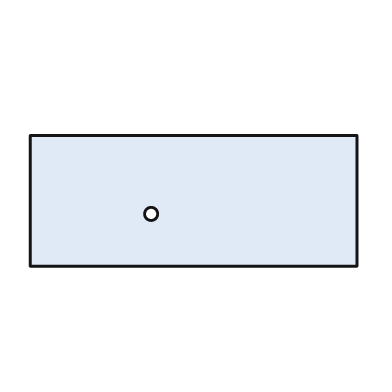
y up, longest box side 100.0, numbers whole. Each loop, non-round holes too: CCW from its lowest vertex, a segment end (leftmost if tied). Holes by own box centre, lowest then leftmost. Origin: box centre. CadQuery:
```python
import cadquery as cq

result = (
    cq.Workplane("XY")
    .moveTo(-50.0, -20.0)
    .lineTo(50.0, -20.0)
    .lineTo(50.0, 20.0)
    .lineTo(-50.0, 20.0)
    .close()
    .moveTo(-13.0, -4.0)
    .circle(2.0)
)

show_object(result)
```